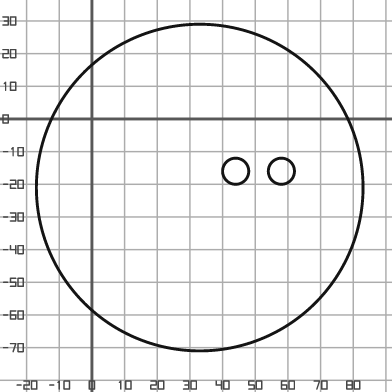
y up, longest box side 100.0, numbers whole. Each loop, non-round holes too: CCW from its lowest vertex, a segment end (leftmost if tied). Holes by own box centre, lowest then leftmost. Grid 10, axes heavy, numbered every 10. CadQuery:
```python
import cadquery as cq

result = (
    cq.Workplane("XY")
    .moveTo(33.0, -21.0)
    .circle(50.0)
    .moveTo(44.0, -16.0)
    .circle(4.0)
    .moveTo(58.0, -16.0)
    .circle(4.0)
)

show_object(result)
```